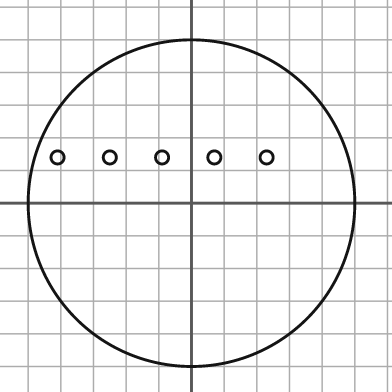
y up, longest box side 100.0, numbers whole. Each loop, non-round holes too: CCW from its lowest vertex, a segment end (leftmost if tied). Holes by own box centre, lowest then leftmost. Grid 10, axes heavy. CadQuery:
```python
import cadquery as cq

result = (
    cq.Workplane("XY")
    .moveTo(0.0, 0.0)
    .circle(50.0)
    .moveTo(-41.0, 14.0)
    .circle(2.0)
    .moveTo(-25.0, 14.0)
    .circle(2.0)
    .moveTo(-9.0, 14.0)
    .circle(2.0)
    .moveTo(7.0, 14.0)
    .circle(2.0)
    .moveTo(23.0, 14.0)
    .circle(2.0)
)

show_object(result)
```